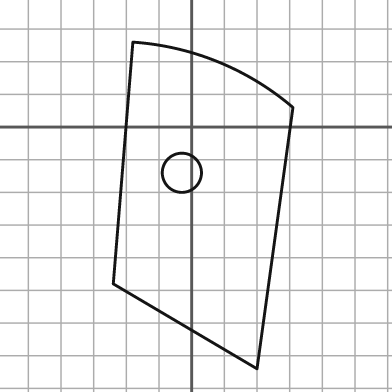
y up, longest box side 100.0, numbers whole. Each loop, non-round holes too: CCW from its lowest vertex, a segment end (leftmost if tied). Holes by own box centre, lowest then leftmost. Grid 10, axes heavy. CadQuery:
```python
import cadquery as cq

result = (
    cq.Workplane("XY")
    .moveTo(20.0, -74.0)
    .lineTo(31.0, 6.0)
    .threePointArc((8.0, 20.0), (-18.0, 26.0))
    .lineTo(-24.0, -48.0)
    .close()
    .moveTo(-3.0, -14.0)
    .circle(6.0)
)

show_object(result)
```